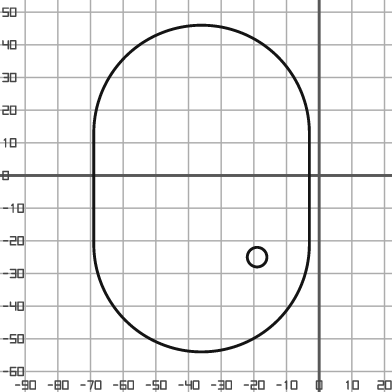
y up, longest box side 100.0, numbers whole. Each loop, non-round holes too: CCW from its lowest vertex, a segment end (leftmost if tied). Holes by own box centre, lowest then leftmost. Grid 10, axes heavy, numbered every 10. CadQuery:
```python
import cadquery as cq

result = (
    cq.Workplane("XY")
    .moveTo(-69.0, -21.0)
    .threePointArc((-36.0, -54.0), (-3.0, -21.0))
    .lineTo(-3.0, 13.0)
    .threePointArc((-36.0, 46.0), (-69.0, 13.0))
    .close()
    .moveTo(-19.0, -25.0)
    .circle(3.0)
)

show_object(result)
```